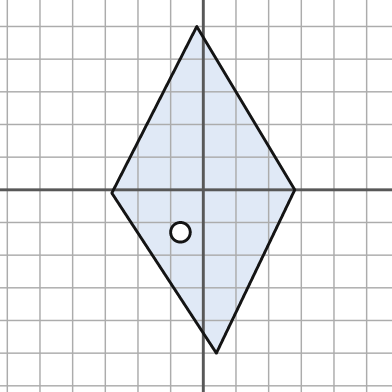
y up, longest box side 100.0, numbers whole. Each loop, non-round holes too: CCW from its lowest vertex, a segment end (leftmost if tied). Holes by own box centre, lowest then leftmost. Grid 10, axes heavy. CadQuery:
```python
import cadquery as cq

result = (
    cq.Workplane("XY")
    .moveTo(4.0, -50.0)
    .lineTo(28.0, 0.0)
    .lineTo(-2.0, 50.0)
    .lineTo(-28.0, -1.0)
    .close()
    .moveTo(-7.0, -13.0)
    .circle(3.0)
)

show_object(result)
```